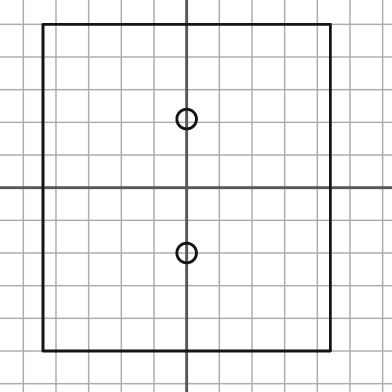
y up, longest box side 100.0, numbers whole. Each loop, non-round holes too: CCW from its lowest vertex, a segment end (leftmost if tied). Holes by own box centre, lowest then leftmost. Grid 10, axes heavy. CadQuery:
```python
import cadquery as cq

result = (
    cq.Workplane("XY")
    .moveTo(-44.0, -50.0)
    .lineTo(44.0, -50.0)
    .lineTo(44.0, 50.0)
    .lineTo(-44.0, 50.0)
    .close()
    .moveTo(0.0, -20.0)
    .circle(3.0)
    .moveTo(0.0, 21.0)
    .circle(3.0)
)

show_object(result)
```